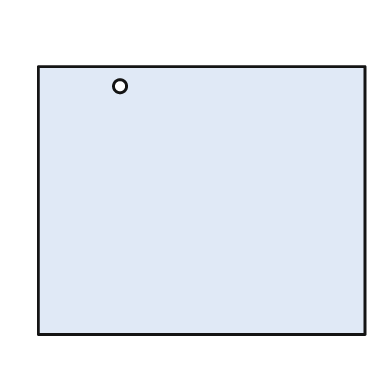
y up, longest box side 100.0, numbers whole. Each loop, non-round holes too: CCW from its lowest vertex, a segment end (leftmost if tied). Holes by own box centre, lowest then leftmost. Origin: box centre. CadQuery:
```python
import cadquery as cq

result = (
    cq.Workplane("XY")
    .moveTo(-50.0, -41.0)
    .lineTo(50.0, -41.0)
    .lineTo(50.0, 41.0)
    .lineTo(-50.0, 41.0)
    .close()
    .moveTo(-25.0, 35.0)
    .circle(2.0)
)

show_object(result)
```